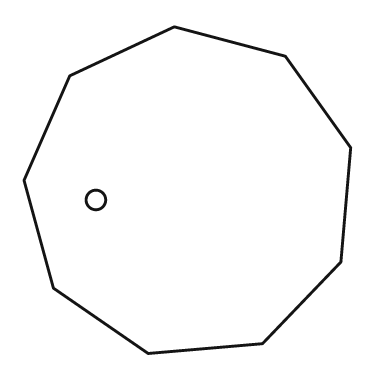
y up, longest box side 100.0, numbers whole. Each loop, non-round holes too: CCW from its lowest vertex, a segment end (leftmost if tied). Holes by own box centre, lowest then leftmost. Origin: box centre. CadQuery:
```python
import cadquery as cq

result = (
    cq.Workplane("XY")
    .moveTo(-12.0, -50.0)
    .lineTo(23.0, -47.0)
    .lineTo(47.0, -22.0)
    .lineTo(50.0, 13.0)
    .lineTo(30.0, 41.0)
    .lineTo(-4.0, 50.0)
    .lineTo(-36.0, 35.0)
    .lineTo(-50.0, 3.0)
    .lineTo(-41.0, -30.0)
    .close()
    .moveTo(-28.0, -3.0)
    .circle(3.0)
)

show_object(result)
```